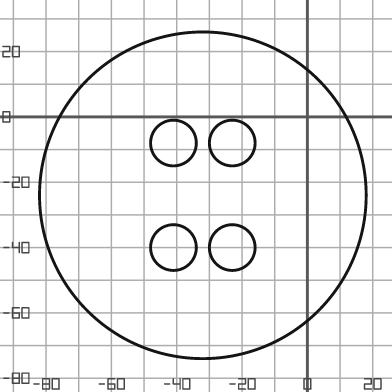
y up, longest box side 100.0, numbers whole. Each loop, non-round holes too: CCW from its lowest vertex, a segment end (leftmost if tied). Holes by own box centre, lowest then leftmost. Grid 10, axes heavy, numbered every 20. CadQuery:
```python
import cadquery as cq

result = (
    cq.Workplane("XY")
    .moveTo(-32.0, -24.0)
    .circle(50.0)
    .moveTo(-41.0, -40.0)
    .circle(7.0)
    .moveTo(-23.0, -40.0)
    .circle(7.0)
    .moveTo(-41.0, -8.0)
    .circle(7.0)
    .moveTo(-23.0, -8.0)
    .circle(7.0)
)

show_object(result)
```